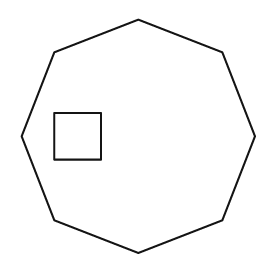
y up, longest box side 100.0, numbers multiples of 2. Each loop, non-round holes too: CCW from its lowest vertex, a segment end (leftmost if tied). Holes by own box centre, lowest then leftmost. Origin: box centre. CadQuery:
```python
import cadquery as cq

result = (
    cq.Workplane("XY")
    .moveTo(0.0, -50.0)
    .lineTo(36.0, -36.0)
    .lineTo(50.0, 0.0)
    .lineTo(36.0, 36.0)
    .lineTo(0.0, 50.0)
    .lineTo(-36.0, 36.0)
    .lineTo(-50.0, 0.0)
    .lineTo(-36.0, -36.0)
    .close()
    .moveTo(-36.0, -10.0)
    .lineTo(-16.0, -10.0)
    .lineTo(-16.0, 10.0)
    .lineTo(-36.0, 10.0)
    .close()
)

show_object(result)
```